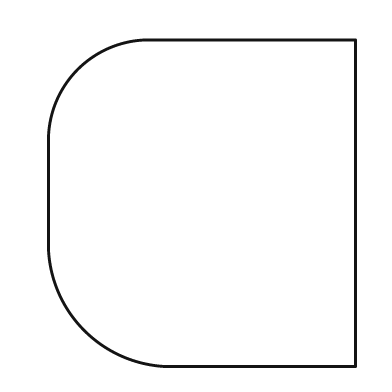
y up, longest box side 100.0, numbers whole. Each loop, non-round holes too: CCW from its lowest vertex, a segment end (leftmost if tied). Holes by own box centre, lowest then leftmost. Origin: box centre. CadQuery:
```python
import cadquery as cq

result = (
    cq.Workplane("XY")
    .moveTo(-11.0, -50.0)
    .lineTo(47.0, -50.0)
    .lineTo(47.0, 50.0)
    .lineTo(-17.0, 50.0)
    .threePointArc((-38.0, 41.0), (-47.0, 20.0))
    .lineTo(-47.0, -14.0)
    .threePointArc((-36.0, -39.0), (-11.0, -50.0))
    .close()
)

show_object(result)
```